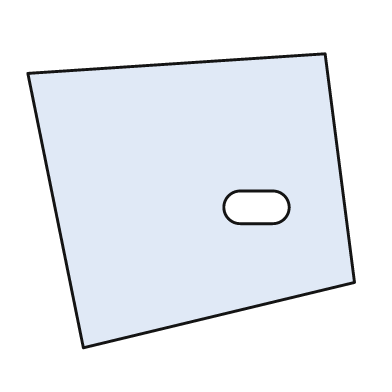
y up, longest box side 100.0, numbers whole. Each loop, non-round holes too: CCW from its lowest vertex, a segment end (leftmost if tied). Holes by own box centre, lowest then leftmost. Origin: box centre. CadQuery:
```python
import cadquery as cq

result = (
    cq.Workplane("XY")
    .moveTo(-33.0, -45.0)
    .lineTo(50.0, -25.0)
    .lineTo(41.0, 45.0)
    .lineTo(-50.0, 39.0)
    .close()
    .moveTo(15.0, -7.0)
    .lineTo(25.0, -7.0)
    .threePointArc((30.0, -2.0), (25.0, 3.0))
    .lineTo(15.0, 3.0)
    .threePointArc((10.0, -2.0), (15.0, -7.0))
    .close()
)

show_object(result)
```